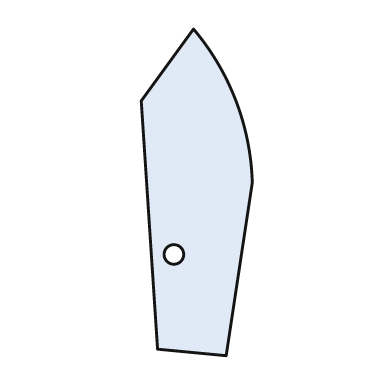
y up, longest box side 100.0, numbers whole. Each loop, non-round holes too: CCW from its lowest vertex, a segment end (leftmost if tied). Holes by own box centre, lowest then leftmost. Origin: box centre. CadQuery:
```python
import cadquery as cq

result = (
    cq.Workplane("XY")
    .moveTo(9.0, -50.0)
    .lineTo(17.0, 3.0)
    .threePointArc((12.0, 28.0), (-1.0, 50.0))
    .lineTo(-17.0, 28.0)
    .lineTo(-12.0, -48.0)
    .close()
    .moveTo(-7.0, -19.0)
    .circle(3.0)
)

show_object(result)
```